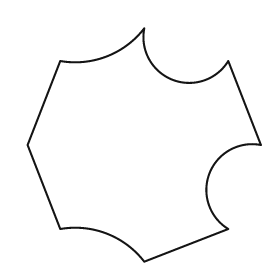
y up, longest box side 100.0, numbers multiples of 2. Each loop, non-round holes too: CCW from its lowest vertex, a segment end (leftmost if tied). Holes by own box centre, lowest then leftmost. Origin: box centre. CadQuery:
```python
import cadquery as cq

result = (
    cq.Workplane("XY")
    .moveTo(0.0, -50.0)
    .lineTo(36.0, -36.0)
    .threePointArc((28.0, -12.0), (50.0, 0.0))
    .lineTo(36.0, 36.0)
    .threePointArc((12.0, 28.0), (0.0, 50.0))
    .threePointArc((-16.0, 38.0), (-36.0, 36.0))
    .lineTo(-50.0, 0.0)
    .lineTo(-36.0, -36.0)
    .threePointArc((-16.0, -38.0), (0.0, -50.0))
    .close()
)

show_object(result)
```